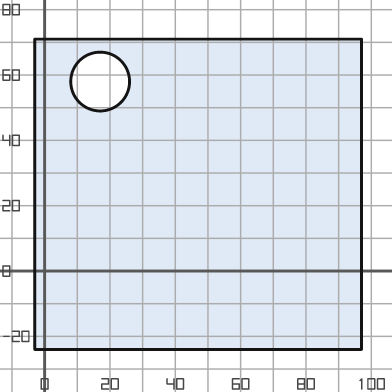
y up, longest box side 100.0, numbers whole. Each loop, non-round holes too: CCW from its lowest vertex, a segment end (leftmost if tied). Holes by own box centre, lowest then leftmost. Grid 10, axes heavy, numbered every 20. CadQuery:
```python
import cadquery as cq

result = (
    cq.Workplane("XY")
    .moveTo(-3.0, -24.0)
    .lineTo(97.0, -24.0)
    .lineTo(97.0, 71.0)
    .lineTo(-3.0, 71.0)
    .close()
    .moveTo(17.0, 58.0)
    .circle(9.0)
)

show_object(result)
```